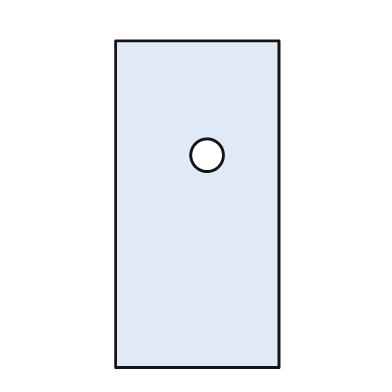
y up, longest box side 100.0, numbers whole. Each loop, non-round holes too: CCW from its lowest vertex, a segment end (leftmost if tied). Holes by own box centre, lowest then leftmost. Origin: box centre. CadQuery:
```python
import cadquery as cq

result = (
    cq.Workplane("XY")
    .moveTo(-25.0, -50.0)
    .lineTo(25.0, -50.0)
    .lineTo(25.0, 50.0)
    .lineTo(-25.0, 50.0)
    .close()
    .moveTo(3.0, 15.0)
    .circle(5.0)
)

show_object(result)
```